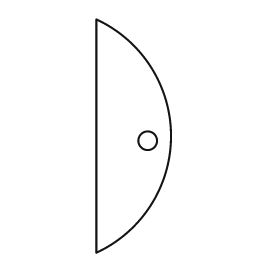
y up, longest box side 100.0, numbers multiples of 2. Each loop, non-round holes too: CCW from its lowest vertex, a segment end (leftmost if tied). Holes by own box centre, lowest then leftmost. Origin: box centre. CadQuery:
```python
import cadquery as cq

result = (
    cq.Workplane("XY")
    .moveTo(-16.0, -50.0)
    .threePointArc((16.0, 0.0), (-16.0, 50.0))
    .close()
    .moveTo(6.0, -2.0)
    .circle(4.0)
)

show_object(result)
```